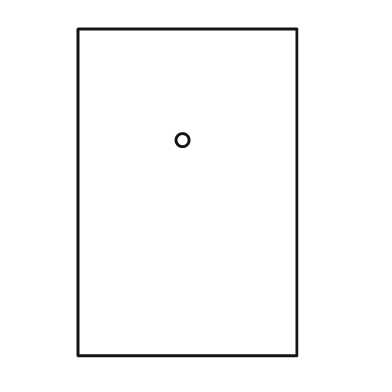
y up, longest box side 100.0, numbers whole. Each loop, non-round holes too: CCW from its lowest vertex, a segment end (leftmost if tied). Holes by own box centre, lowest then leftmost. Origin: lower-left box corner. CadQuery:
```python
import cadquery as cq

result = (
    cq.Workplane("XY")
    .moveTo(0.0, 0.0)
    .lineTo(67.0, 0.0)
    .lineTo(67.0, 100.0)
    .lineTo(0.0, 100.0)
    .close()
    .moveTo(32.0, 66.0)
    .circle(2.0)
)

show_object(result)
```